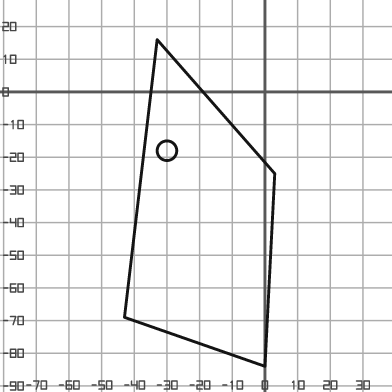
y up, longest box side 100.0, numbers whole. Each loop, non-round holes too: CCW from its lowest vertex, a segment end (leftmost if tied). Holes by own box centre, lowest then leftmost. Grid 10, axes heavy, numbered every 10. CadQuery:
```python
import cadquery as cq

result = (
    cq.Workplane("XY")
    .moveTo(0.0, -84.0)
    .lineTo(3.0, -25.0)
    .lineTo(-33.0, 16.0)
    .lineTo(-43.0, -69.0)
    .close()
    .moveTo(-30.0, -18.0)
    .circle(3.0)
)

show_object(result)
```